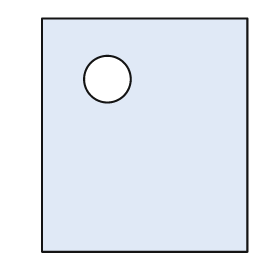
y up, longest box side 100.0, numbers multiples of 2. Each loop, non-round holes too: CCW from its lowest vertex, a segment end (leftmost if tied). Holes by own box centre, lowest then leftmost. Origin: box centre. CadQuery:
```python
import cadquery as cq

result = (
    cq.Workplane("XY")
    .moveTo(-44.0, -50.0)
    .lineTo(44.0, -50.0)
    .lineTo(44.0, 50.0)
    .lineTo(-44.0, 50.0)
    .close()
    .moveTo(-16.0, 24.0)
    .circle(10.0)
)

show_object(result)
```